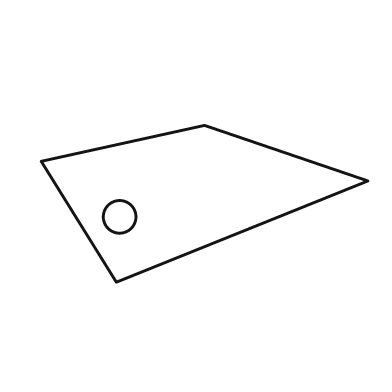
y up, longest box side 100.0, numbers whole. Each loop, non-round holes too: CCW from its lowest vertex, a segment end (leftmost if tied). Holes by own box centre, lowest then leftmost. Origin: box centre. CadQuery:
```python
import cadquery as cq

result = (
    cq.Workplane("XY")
    .moveTo(-27.0, -24.0)
    .lineTo(50.0, 7.0)
    .lineTo(0.0, 24.0)
    .lineTo(-50.0, 13.0)
    .close()
    .moveTo(-26.0, -4.0)
    .circle(5.0)
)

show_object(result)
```